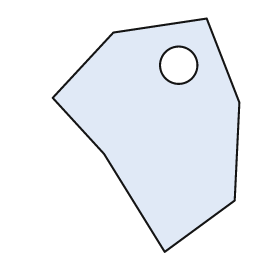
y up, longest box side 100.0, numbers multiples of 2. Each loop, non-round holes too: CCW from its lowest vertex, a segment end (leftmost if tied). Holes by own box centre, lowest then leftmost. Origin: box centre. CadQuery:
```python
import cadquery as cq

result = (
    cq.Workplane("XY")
    .moveTo(8.0, -50.0)
    .lineTo(38.0, -28.0)
    .lineTo(40.0, 14.0)
    .lineTo(26.0, 50.0)
    .lineTo(-14.0, 44.0)
    .lineTo(-40.0, 16.0)
    .lineTo(-18.0, -8.0)
    .close()
    .moveTo(14.0, 30.0)
    .circle(8.0)
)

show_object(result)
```